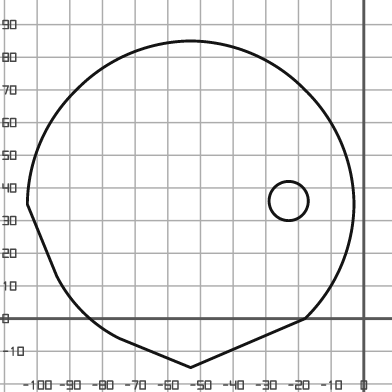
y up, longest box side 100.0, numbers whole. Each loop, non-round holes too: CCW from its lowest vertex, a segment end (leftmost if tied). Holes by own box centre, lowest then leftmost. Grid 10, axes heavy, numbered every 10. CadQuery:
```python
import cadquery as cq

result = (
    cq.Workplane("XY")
    .moveTo(-53.0, -15.0)
    .lineTo(-18.0, 0.0)
    .threePointArc((-7.0, 16.0), (-3.0, 35.0))
    .threePointArc((-7.0, 54.0), (-18.0, 70.0))
    .threePointArc((-34.0, 81.0), (-53.0, 85.0))
    .threePointArc((-72.0, 81.0), (-88.0, 70.0))
    .threePointArc((-99.0, 54.0), (-103.0, 35.0))
    .lineTo(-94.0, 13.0)
    .threePointArc((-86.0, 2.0), (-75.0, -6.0))
    .close()
    .moveTo(-23.0, 36.0)
    .circle(6.0)
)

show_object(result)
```